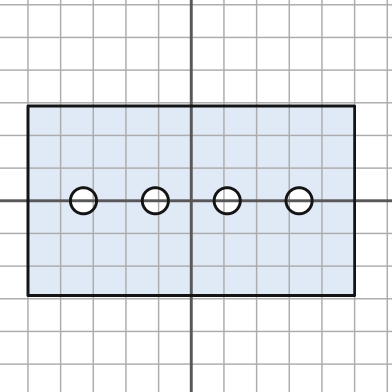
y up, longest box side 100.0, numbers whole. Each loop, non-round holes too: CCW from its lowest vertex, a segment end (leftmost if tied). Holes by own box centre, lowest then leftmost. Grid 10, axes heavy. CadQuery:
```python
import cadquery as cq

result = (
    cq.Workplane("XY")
    .moveTo(-50.0, -29.0)
    .lineTo(50.0, -29.0)
    .lineTo(50.0, 29.0)
    .lineTo(-50.0, 29.0)
    .close()
    .moveTo(-33.0, 0.0)
    .circle(4.0)
    .moveTo(-11.0, 0.0)
    .circle(4.0)
    .moveTo(11.0, 0.0)
    .circle(4.0)
    .moveTo(33.0, 0.0)
    .circle(4.0)
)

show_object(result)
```